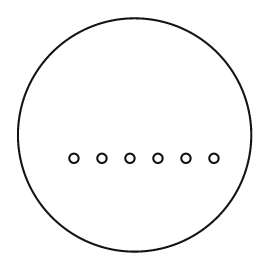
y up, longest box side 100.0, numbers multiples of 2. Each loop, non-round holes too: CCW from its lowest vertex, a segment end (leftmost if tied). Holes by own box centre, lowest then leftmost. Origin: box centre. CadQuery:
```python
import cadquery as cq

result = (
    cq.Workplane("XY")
    .moveTo(0.0, 0.0)
    .circle(50.0)
    .moveTo(-26.0, -10.0)
    .circle(2.0)
    .moveTo(-14.0, -10.0)
    .circle(2.0)
    .moveTo(-2.0, -10.0)
    .circle(2.0)
    .moveTo(10.0, -10.0)
    .circle(2.0)
    .moveTo(22.0, -10.0)
    .circle(2.0)
    .moveTo(34.0, -10.0)
    .circle(2.0)
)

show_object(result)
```